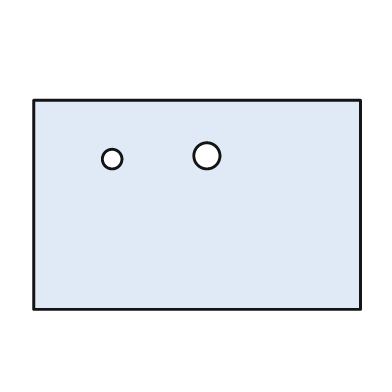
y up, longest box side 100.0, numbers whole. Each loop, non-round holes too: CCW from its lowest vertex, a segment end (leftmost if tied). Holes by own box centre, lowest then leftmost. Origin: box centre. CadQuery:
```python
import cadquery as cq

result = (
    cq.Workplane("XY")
    .moveTo(-50.0, -32.0)
    .lineTo(50.0, -32.0)
    .lineTo(50.0, 32.0)
    .lineTo(-50.0, 32.0)
    .close()
    .moveTo(-26.0, 14.0)
    .circle(3.0)
    .moveTo(3.0, 15.0)
    .circle(4.0)
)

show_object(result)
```